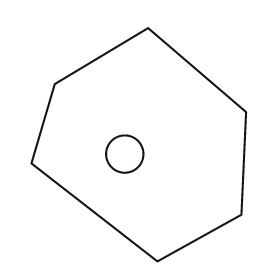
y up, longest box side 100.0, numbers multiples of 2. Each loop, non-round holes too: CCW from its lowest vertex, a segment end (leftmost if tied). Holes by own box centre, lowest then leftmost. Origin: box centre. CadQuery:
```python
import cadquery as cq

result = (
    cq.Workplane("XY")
    .moveTo(8.0, -50.0)
    .lineTo(44.0, -30.0)
    .lineTo(46.0, 14.0)
    .lineTo(4.0, 50.0)
    .lineTo(-36.0, 26.0)
    .lineTo(-46.0, -8.0)
    .close()
    .moveTo(-6.0, -4.0)
    .circle(8.0)
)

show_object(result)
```